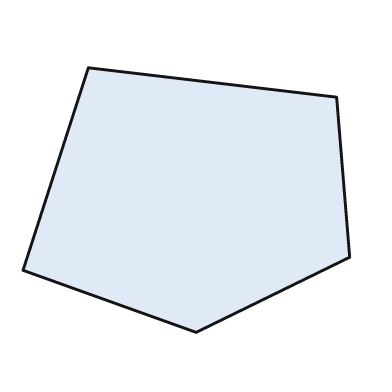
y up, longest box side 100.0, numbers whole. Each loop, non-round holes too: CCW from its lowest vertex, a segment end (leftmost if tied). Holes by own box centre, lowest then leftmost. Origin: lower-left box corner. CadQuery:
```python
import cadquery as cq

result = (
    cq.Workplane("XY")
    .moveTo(53.0, 0.0)
    .lineTo(100.0, 23.0)
    .lineTo(96.0, 72.0)
    .lineTo(20.0, 81.0)
    .lineTo(0.0, 19.0)
    .close()
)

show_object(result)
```